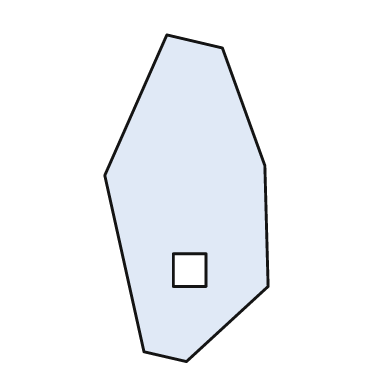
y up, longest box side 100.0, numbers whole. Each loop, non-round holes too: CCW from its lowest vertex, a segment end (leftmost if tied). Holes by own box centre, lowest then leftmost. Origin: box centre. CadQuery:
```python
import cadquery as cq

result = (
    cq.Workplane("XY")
    .moveTo(0.0, -50.0)
    .lineTo(25.0, -27.0)
    .lineTo(24.0, 10.0)
    .lineTo(11.0, 46.0)
    .lineTo(-6.0, 50.0)
    .lineTo(-25.0, 7.0)
    .lineTo(-13.0, -47.0)
    .close()
    .moveTo(-4.0, -27.0)
    .lineTo(6.0, -27.0)
    .lineTo(6.0, -17.0)
    .lineTo(-4.0, -17.0)
    .close()
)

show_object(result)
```